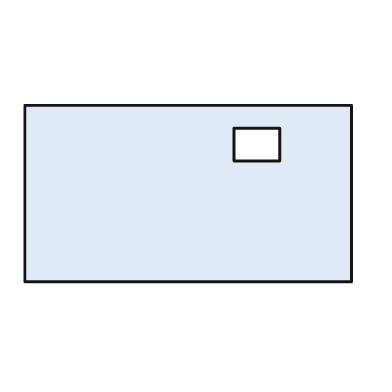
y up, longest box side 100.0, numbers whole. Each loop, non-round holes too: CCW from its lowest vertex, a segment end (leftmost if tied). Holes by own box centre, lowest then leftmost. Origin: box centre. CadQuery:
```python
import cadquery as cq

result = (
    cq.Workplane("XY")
    .moveTo(-50.0, -27.0)
    .lineTo(50.0, -27.0)
    .lineTo(50.0, 27.0)
    .lineTo(-50.0, 27.0)
    .close()
    .moveTo(14.0, 10.0)
    .lineTo(28.0, 10.0)
    .lineTo(28.0, 20.0)
    .lineTo(14.0, 20.0)
    .close()
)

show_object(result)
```